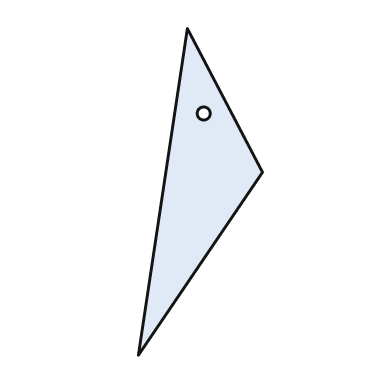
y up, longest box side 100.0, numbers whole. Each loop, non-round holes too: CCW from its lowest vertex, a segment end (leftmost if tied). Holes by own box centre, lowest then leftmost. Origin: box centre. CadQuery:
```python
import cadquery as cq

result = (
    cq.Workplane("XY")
    .moveTo(-19.0, -50.0)
    .lineTo(19.0, 6.0)
    .lineTo(-4.0, 50.0)
    .close()
    .moveTo(1.0, 24.0)
    .circle(2.0)
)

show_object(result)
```